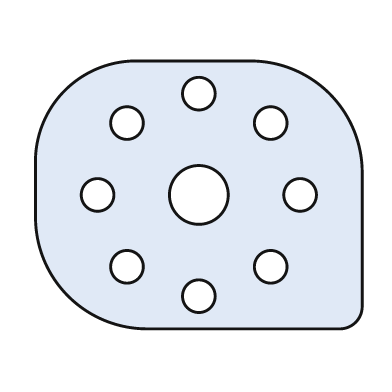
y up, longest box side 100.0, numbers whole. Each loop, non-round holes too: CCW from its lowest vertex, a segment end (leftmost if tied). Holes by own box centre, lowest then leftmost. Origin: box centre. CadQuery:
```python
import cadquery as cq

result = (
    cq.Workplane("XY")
    .moveTo(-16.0, -41.0)
    .lineTo(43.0, -41.0)
    .threePointArc((48.0, -39.0), (50.0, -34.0))
    .lineTo(50.0, 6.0)
    .threePointArc((40.0, 31.0), (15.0, 41.0))
    .lineTo(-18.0, 41.0)
    .threePointArc((-41.0, 32.0), (-50.0, 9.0))
    .lineTo(-50.0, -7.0)
    .threePointArc((-40.0, -31.0), (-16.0, -41.0))
    .close()
    .moveTo(0.0, -31.0)
    .circle(5.0)
    .moveTo(-22.0, -22.0)
    .circle(5.0)
    .moveTo(22.0, -22.0)
    .circle(5.0)
    .moveTo(-31.0, 0.0)
    .circle(5.0)
    .moveTo(0.0, 0.0)
    .circle(9.0)
    .moveTo(31.0, 0.0)
    .circle(5.0)
    .moveTo(-22.0, 22.0)
    .circle(5.0)
    .moveTo(22.0, 22.0)
    .circle(5.0)
    .moveTo(0.0, 31.0)
    .circle(5.0)
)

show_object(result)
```